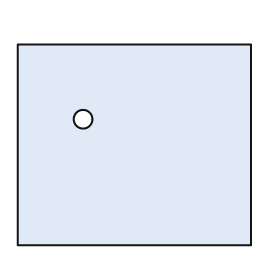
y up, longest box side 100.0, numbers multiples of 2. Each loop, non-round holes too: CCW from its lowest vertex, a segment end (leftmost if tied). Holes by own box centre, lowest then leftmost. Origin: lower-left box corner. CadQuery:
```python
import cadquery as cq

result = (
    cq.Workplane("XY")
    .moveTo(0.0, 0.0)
    .lineTo(100.0, 0.0)
    .lineTo(100.0, 86.0)
    .lineTo(0.0, 86.0)
    .close()
    .moveTo(28.0, 54.0)
    .circle(4.0)
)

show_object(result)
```